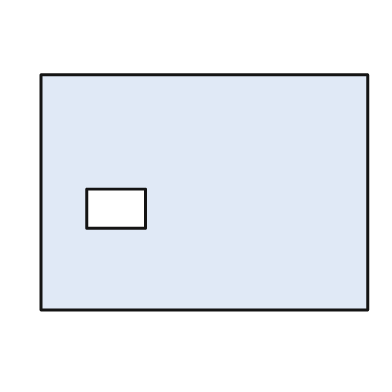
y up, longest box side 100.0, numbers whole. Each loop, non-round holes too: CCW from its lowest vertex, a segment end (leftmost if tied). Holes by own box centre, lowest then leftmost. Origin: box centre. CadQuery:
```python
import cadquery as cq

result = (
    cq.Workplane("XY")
    .moveTo(-50.0, -36.0)
    .lineTo(50.0, -36.0)
    .lineTo(50.0, 36.0)
    .lineTo(-50.0, 36.0)
    .close()
    .moveTo(-36.0, -11.0)
    .lineTo(-18.0, -11.0)
    .lineTo(-18.0, 1.0)
    .lineTo(-36.0, 1.0)
    .close()
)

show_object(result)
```